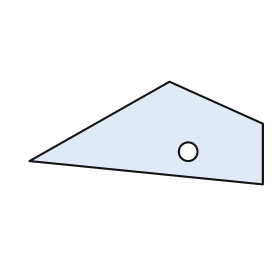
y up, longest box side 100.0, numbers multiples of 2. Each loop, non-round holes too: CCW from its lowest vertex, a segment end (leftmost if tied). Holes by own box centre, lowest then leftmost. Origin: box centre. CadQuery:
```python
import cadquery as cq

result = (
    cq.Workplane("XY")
    .moveTo(50.0, -22.0)
    .lineTo(50.0, 4.0)
    .lineTo(10.0, 22.0)
    .lineTo(-50.0, -12.0)
    .close()
    .moveTo(18.0, -8.0)
    .circle(4.0)
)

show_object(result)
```